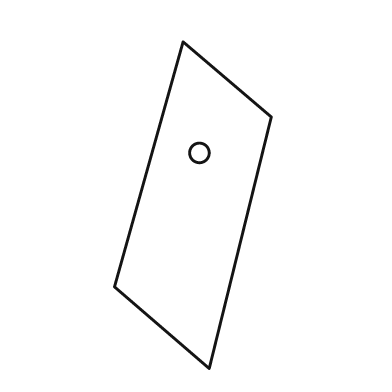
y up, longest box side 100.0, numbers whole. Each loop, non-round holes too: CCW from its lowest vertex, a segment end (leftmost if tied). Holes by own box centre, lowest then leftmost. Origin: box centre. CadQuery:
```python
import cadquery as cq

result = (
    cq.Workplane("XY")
    .moveTo(5.0, -50.0)
    .lineTo(24.0, 27.0)
    .lineTo(-3.0, 50.0)
    .lineTo(-24.0, -25.0)
    .close()
    .moveTo(2.0, 16.0)
    .circle(3.0)
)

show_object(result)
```